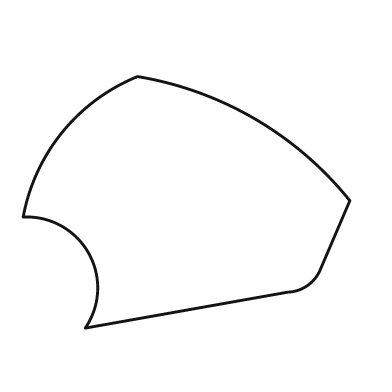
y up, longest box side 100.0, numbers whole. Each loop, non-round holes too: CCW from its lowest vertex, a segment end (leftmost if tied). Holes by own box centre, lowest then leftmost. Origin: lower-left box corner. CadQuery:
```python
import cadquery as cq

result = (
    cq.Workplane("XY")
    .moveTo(19.0, 0.0)
    .lineTo(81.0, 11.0)
    .threePointArc((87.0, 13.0), (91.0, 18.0))
    .lineTo(100.0, 39.0)
    .threePointArc((71.0, 64.0), (35.0, 77.0))
    .threePointArc((12.0, 60.0), (0.0, 34.0))
    .threePointArc((20.0, 23.0), (19.0, 0.0))
    .close()
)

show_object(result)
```